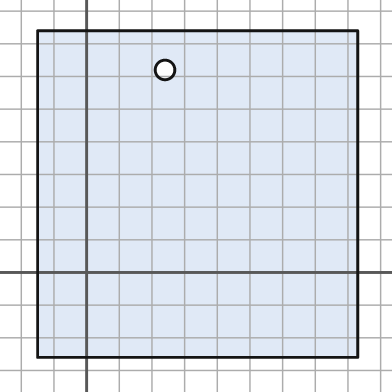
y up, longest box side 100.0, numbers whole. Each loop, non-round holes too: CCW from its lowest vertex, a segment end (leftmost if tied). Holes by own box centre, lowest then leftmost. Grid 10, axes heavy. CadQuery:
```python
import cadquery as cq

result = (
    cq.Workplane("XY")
    .moveTo(-15.0, -26.0)
    .lineTo(83.0, -26.0)
    .lineTo(83.0, 74.0)
    .lineTo(-15.0, 74.0)
    .close()
    .moveTo(24.0, 62.0)
    .circle(3.0)
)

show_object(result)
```